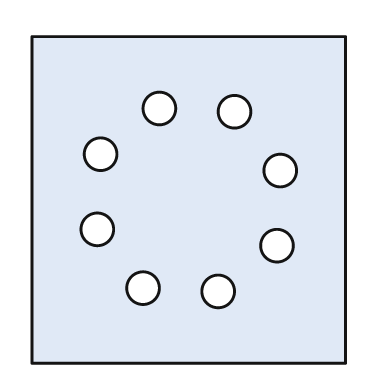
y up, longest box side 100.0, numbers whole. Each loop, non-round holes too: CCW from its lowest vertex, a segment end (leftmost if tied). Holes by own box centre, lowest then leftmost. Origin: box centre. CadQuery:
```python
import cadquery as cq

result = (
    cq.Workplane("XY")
    .moveTo(-48.0, -50.0)
    .lineTo(48.0, -50.0)
    .lineTo(48.0, 50.0)
    .lineTo(-48.0, 50.0)
    .close()
    .moveTo(9.0, -28.0)
    .circle(5.0)
    .moveTo(-14.0, -27.0)
    .circle(5.0)
    .moveTo(27.0, -14.0)
    .circle(5.0)
    .moveTo(-28.0, -9.0)
    .circle(5.0)
    .moveTo(28.0, 9.0)
    .circle(5.0)
    .moveTo(-27.0, 14.0)
    .circle(5.0)
    .moveTo(14.0, 27.0)
    .circle(5.0)
    .moveTo(-9.0, 28.0)
    .circle(5.0)
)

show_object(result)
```